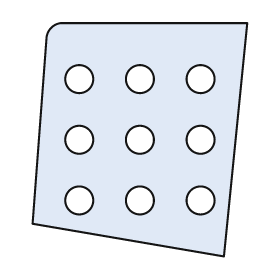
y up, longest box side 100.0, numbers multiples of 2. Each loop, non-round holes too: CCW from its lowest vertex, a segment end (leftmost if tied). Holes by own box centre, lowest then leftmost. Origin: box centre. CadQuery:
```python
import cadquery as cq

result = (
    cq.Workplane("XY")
    .moveTo(36.0, -50.0)
    .lineTo(46.0, 50.0)
    .lineTo(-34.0, 50.0)
    .threePointArc((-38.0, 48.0), (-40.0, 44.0))
    .lineTo(-46.0, -36.0)
    .close()
    .moveTo(-26.0, -26.0)
    .circle(6.0)
    .moveTo(0.0, -26.0)
    .circle(6.0)
    .moveTo(26.0, -26.0)
    .circle(6.0)
    .moveTo(-26.0, 0.0)
    .circle(6.0)
    .moveTo(0.0, 0.0)
    .circle(6.0)
    .moveTo(26.0, 0.0)
    .circle(6.0)
    .moveTo(-26.0, 26.0)
    .circle(6.0)
    .moveTo(0.0, 26.0)
    .circle(6.0)
    .moveTo(26.0, 26.0)
    .circle(6.0)
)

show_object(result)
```